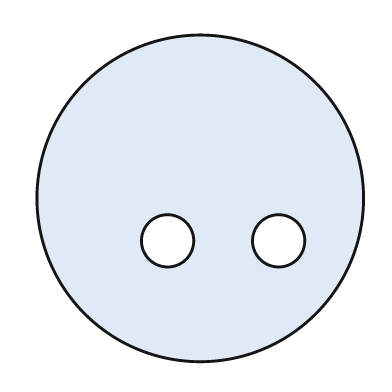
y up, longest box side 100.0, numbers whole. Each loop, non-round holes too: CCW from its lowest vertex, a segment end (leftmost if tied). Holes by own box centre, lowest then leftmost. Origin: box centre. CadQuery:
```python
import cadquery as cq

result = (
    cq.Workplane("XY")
    .moveTo(0.0, 0.0)
    .circle(50.0)
    .moveTo(-10.0, -13.0)
    .circle(8.0)
    .moveTo(24.0, -13.0)
    .circle(8.0)
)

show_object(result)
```